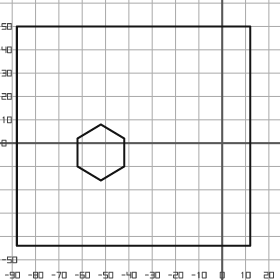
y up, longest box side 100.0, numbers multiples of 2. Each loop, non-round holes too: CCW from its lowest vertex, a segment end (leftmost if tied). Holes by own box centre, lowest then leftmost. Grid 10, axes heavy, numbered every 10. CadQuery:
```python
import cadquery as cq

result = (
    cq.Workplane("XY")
    .moveTo(-88.0, -44.0)
    .lineTo(12.0, -44.0)
    .lineTo(12.0, 50.0)
    .lineTo(-88.0, 50.0)
    .close()
    .moveTo(-52.0, -16.0)
    .lineTo(-42.0, -10.0)
    .lineTo(-42.0, 2.0)
    .lineTo(-52.0, 8.0)
    .lineTo(-62.0, 2.0)
    .lineTo(-62.0, -10.0)
    .close()
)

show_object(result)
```